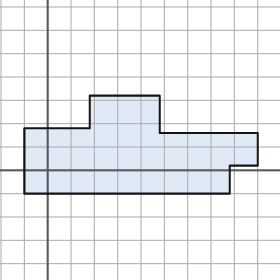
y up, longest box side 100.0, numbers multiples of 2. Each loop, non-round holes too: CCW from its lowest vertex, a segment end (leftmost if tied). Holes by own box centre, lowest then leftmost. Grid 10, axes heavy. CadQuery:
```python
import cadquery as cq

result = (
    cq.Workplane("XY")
    .moveTo(-10.0, -10.0)
    .lineTo(78.0, -10.0)
    .lineTo(78.0, 2.0)
    .lineTo(90.0, 2.0)
    .lineTo(90.0, 16.0)
    .lineTo(48.0, 16.0)
    .lineTo(48.0, 32.0)
    .lineTo(18.0, 32.0)
    .lineTo(18.0, 18.0)
    .lineTo(-10.0, 18.0)
    .close()
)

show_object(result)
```